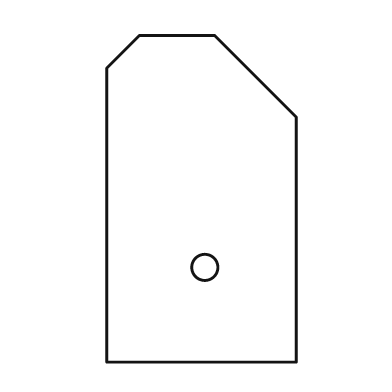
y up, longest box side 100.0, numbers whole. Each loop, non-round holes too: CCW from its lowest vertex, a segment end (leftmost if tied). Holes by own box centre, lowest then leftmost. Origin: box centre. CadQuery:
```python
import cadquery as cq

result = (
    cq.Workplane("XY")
    .moveTo(-29.0, -50.0)
    .lineTo(29.0, -50.0)
    .lineTo(29.0, 25.0)
    .lineTo(4.0, 50.0)
    .lineTo(-19.0, 50.0)
    .lineTo(-29.0, 40.0)
    .close()
    .moveTo(1.0, -21.0)
    .circle(4.0)
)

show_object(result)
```